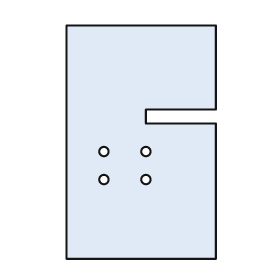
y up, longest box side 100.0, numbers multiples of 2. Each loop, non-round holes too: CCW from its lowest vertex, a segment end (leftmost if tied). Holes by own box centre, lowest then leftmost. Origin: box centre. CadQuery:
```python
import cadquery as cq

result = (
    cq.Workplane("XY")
    .moveTo(-32.0, -50.0)
    .lineTo(32.0, -50.0)
    .lineTo(32.0, 8.0)
    .lineTo(2.0, 8.0)
    .lineTo(2.0, 14.0)
    .lineTo(32.0, 14.0)
    .lineTo(32.0, 50.0)
    .lineTo(-32.0, 50.0)
    .close()
    .moveTo(-16.0, -16.0)
    .circle(2.0)
    .moveTo(2.0, -16.0)
    .circle(2.0)
    .moveTo(-16.0, -4.0)
    .circle(2.0)
    .moveTo(2.0, -4.0)
    .circle(2.0)
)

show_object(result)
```